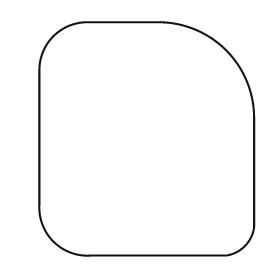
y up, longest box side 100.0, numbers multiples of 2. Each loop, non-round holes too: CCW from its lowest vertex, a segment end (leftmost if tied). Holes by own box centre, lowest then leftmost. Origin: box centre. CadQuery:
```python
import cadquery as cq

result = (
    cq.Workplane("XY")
    .moveTo(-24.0, -50.0)
    .lineTo(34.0, -50.0)
    .threePointArc((42.0, -46.0), (46.0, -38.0))
    .lineTo(46.0, 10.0)
    .threePointArc((34.0, 38.0), (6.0, 50.0))
    .lineTo(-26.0, 50.0)
    .threePointArc((-40.0, 44.0), (-46.0, 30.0))
    .lineTo(-46.0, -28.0)
    .threePointArc((-40.0, -44.0), (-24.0, -50.0))
    .close()
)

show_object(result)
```